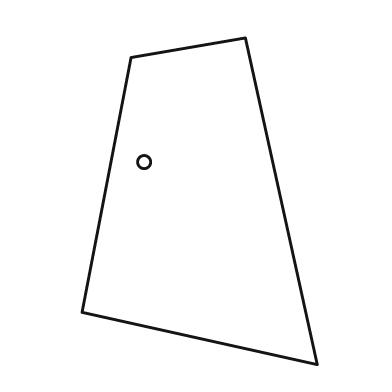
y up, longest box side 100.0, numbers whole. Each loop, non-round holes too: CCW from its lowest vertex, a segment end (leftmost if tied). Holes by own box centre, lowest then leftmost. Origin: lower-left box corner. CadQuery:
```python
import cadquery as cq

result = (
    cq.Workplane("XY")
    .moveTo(72.0, 0.0)
    .lineTo(50.0, 100.0)
    .lineTo(15.0, 94.0)
    .lineTo(0.0, 16.0)
    .close()
    .moveTo(19.0, 62.0)
    .circle(2.0)
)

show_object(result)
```